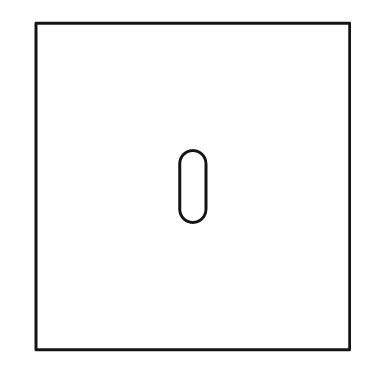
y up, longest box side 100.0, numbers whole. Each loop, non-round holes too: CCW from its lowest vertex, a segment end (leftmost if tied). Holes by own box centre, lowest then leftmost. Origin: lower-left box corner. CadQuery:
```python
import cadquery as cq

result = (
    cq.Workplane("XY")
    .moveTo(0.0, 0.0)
    .lineTo(96.0, 0.0)
    .lineTo(96.0, 100.0)
    .lineTo(0.0, 100.0)
    .close()
    .moveTo(44.0, 43.0)
    .threePointArc((48.0, 39.0), (52.0, 43.0))
    .lineTo(52.0, 57.0)
    .threePointArc((48.0, 61.0), (44.0, 57.0))
    .close()
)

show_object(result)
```